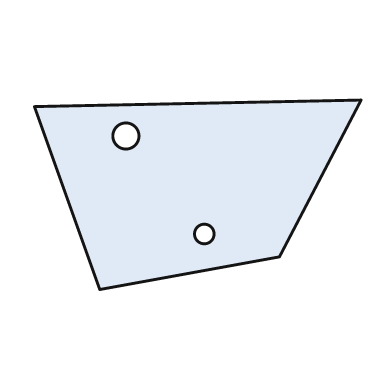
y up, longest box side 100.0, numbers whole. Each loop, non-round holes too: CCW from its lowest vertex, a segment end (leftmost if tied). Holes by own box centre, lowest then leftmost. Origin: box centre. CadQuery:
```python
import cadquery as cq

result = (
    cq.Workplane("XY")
    .moveTo(-30.0, -29.0)
    .lineTo(25.0, -19.0)
    .lineTo(50.0, 29.0)
    .lineTo(-50.0, 27.0)
    .close()
    .moveTo(2.0, -12.0)
    .circle(3.0)
    .moveTo(-22.0, 18.0)
    .circle(4.0)
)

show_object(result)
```